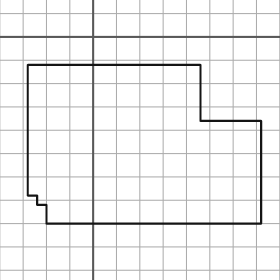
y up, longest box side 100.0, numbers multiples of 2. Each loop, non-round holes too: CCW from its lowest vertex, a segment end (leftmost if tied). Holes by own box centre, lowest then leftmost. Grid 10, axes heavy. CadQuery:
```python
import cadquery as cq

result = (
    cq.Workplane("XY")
    .moveTo(-20.0, -80.0)
    .lineTo(72.0, -80.0)
    .lineTo(72.0, -36.0)
    .lineTo(46.0, -36.0)
    .lineTo(46.0, -12.0)
    .lineTo(-28.0, -12.0)
    .lineTo(-28.0, -68.0)
    .lineTo(-24.0, -68.0)
    .lineTo(-24.0, -72.0)
    .lineTo(-20.0, -72.0)
    .close()
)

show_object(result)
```